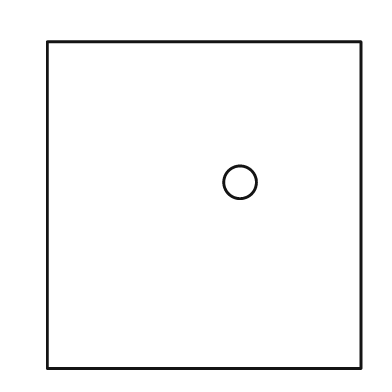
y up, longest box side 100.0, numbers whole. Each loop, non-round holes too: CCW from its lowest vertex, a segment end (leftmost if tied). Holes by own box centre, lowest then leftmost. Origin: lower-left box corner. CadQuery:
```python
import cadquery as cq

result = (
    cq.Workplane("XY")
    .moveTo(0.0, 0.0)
    .lineTo(96.0, 0.0)
    .lineTo(96.0, 100.0)
    .lineTo(0.0, 100.0)
    .close()
    .moveTo(59.0, 57.0)
    .circle(5.0)
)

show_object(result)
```